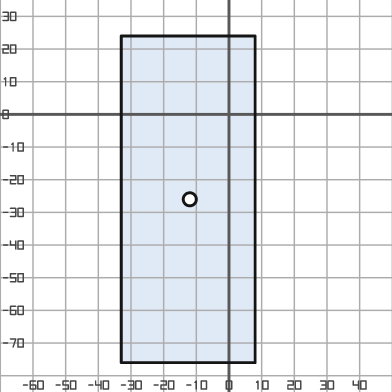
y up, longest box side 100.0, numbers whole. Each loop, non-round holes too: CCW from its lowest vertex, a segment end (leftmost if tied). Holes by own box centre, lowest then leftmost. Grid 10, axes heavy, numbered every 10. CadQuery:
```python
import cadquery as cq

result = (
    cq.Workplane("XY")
    .moveTo(-33.0, -76.0)
    .lineTo(8.0, -76.0)
    .lineTo(8.0, 24.0)
    .lineTo(-33.0, 24.0)
    .close()
    .moveTo(-12.0, -26.0)
    .circle(2.0)
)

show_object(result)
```